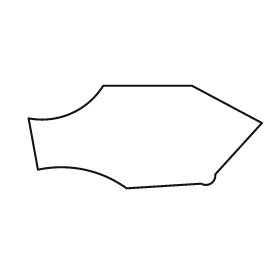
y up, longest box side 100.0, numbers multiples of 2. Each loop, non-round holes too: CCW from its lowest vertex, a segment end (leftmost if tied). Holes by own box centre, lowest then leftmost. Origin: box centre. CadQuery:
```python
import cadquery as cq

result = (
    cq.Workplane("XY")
    .moveTo(-8.0, -22.0)
    .lineTo(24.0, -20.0)
    .threePointArc((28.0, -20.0), (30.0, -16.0))
    .lineTo(50.0, 6.0)
    .lineTo(20.0, 22.0)
    .lineTo(-18.0, 22.0)
    .threePointArc((-32.0, 10.0), (-50.0, 8.0))
    .lineTo(-46.0, -14.0)
    .threePointArc((-26.0, -14.0), (-8.0, -22.0))
    .close()
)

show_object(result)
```